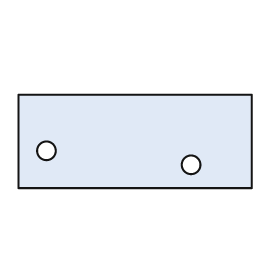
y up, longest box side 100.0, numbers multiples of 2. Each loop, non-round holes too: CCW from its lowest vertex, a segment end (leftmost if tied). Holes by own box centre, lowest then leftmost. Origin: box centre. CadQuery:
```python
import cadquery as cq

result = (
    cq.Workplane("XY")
    .moveTo(-50.0, -20.0)
    .lineTo(50.0, -20.0)
    .lineTo(50.0, 20.0)
    .lineTo(-50.0, 20.0)
    .close()
    .moveTo(24.0, -10.0)
    .circle(4.0)
    .moveTo(-38.0, -4.0)
    .circle(4.0)
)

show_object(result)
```